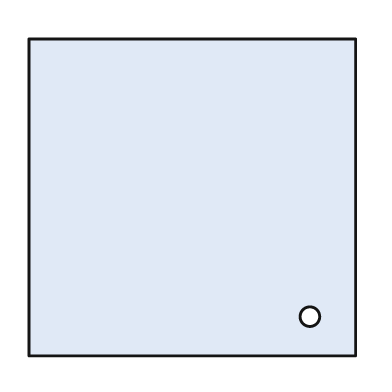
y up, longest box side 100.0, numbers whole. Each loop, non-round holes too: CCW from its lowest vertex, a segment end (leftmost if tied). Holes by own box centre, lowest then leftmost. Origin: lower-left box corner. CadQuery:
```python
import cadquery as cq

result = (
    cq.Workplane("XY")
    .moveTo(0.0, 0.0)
    .lineTo(100.0, 0.0)
    .lineTo(100.0, 97.0)
    .lineTo(0.0, 97.0)
    .close()
    .moveTo(86.0, 12.0)
    .circle(3.0)
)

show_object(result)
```